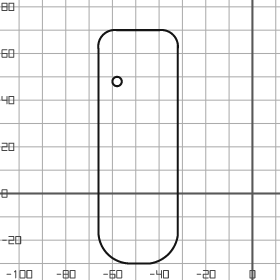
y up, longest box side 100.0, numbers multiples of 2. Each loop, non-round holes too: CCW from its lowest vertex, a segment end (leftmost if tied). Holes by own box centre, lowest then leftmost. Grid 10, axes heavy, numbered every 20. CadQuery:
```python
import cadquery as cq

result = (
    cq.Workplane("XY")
    .moveTo(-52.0, -30.0)
    .lineTo(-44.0, -30.0)
    .threePointArc((-36.0, -26.0), (-32.0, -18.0))
    .lineTo(-32.0, 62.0)
    .threePointArc((-34.0, 68.0), (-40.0, 70.0))
    .lineTo(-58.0, 70.0)
    .threePointArc((-64.0, 68.0), (-66.0, 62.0))
    .lineTo(-66.0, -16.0)
    .threePointArc((-62.0, -26.0), (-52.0, -30.0))
    .close()
    .moveTo(-58.0, 48.0)
    .circle(2.0)
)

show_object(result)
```